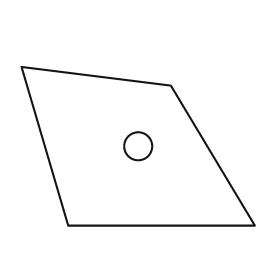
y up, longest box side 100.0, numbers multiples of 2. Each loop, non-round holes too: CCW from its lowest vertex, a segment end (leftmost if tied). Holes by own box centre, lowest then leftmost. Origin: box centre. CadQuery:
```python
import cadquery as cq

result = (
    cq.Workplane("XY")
    .moveTo(-30.0, -34.0)
    .lineTo(50.0, -34.0)
    .lineTo(14.0, 26.0)
    .lineTo(-50.0, 34.0)
    .close()
    .moveTo(0.0, 0.0)
    .circle(6.0)
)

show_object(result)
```